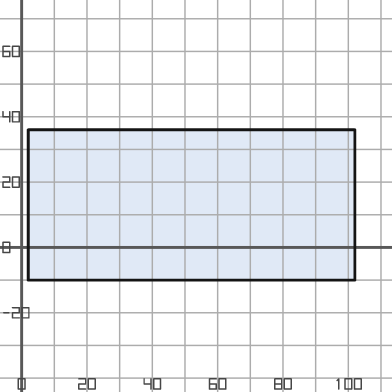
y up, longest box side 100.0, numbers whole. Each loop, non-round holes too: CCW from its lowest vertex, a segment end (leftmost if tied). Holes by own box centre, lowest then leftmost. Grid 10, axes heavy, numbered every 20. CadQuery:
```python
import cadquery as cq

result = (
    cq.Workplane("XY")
    .moveTo(2.0, -10.0)
    .lineTo(102.0, -10.0)
    .lineTo(102.0, 36.0)
    .lineTo(2.0, 36.0)
    .close()
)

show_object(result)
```